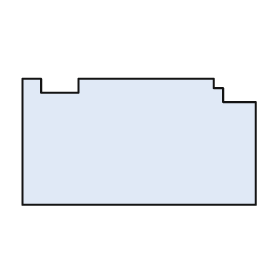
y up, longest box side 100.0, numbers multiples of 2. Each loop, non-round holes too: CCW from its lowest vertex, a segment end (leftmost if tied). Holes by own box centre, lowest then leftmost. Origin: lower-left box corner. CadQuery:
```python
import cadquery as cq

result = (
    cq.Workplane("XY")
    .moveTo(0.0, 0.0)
    .lineTo(100.0, 0.0)
    .lineTo(100.0, 44.0)
    .lineTo(86.0, 44.0)
    .lineTo(86.0, 50.0)
    .lineTo(82.0, 50.0)
    .lineTo(82.0, 54.0)
    .lineTo(24.0, 54.0)
    .lineTo(24.0, 48.0)
    .lineTo(8.0, 48.0)
    .lineTo(8.0, 54.0)
    .lineTo(0.0, 54.0)
    .close()
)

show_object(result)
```